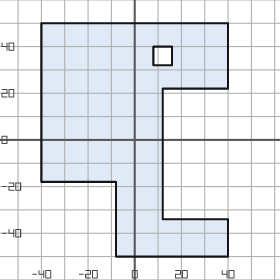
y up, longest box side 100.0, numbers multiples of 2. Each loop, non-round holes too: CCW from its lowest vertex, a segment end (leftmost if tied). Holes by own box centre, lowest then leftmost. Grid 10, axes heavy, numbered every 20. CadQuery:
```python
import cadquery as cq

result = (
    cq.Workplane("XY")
    .moveTo(-8.0, -50.0)
    .lineTo(40.0, -50.0)
    .lineTo(40.0, -34.0)
    .lineTo(12.0, -34.0)
    .lineTo(12.0, 22.0)
    .lineTo(40.0, 22.0)
    .lineTo(40.0, 50.0)
    .lineTo(-40.0, 50.0)
    .lineTo(-40.0, -18.0)
    .lineTo(-8.0, -18.0)
    .close()
    .moveTo(8.0, 32.0)
    .lineTo(16.0, 32.0)
    .lineTo(16.0, 40.0)
    .lineTo(8.0, 40.0)
    .close()
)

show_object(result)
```